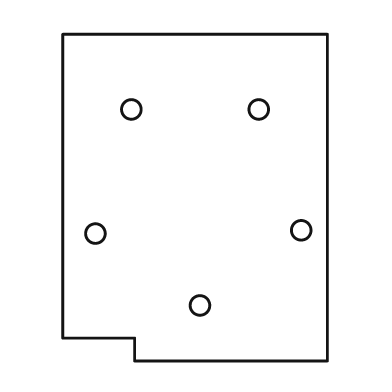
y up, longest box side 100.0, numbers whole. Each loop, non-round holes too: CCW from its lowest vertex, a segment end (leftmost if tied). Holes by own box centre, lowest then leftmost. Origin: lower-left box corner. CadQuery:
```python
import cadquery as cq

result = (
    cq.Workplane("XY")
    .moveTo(22.0, 0.0)
    .lineTo(81.0, 0.0)
    .lineTo(81.0, 100.0)
    .lineTo(0.0, 100.0)
    .lineTo(0.0, 7.0)
    .lineTo(22.0, 7.0)
    .close()
    .moveTo(42.0, 17.0)
    .circle(3.0)
    .moveTo(10.0, 39.0)
    .circle(3.0)
    .moveTo(73.0, 40.0)
    .circle(3.0)
    .moveTo(21.0, 77.0)
    .circle(3.0)
    .moveTo(60.0, 77.0)
    .circle(3.0)
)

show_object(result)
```